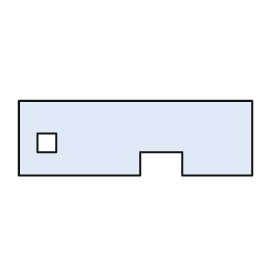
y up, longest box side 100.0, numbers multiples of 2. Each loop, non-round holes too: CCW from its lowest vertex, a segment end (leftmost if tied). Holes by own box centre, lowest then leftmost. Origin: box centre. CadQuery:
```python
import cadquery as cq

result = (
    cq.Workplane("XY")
    .moveTo(-50.0, -16.0)
    .lineTo(2.0, -16.0)
    .lineTo(2.0, -6.0)
    .lineTo(20.0, -6.0)
    .lineTo(20.0, -16.0)
    .lineTo(50.0, -16.0)
    .lineTo(50.0, 16.0)
    .lineTo(-50.0, 16.0)
    .close()
    .moveTo(-42.0, -6.0)
    .lineTo(-34.0, -6.0)
    .lineTo(-34.0, 2.0)
    .lineTo(-42.0, 2.0)
    .close()
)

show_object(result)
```